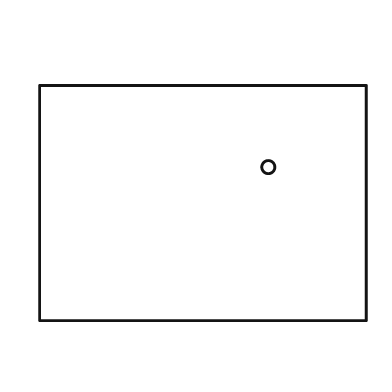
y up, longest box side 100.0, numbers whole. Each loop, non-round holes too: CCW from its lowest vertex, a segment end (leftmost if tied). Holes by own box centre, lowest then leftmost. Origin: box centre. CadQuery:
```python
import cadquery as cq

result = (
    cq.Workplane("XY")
    .moveTo(-50.0, -36.0)
    .lineTo(50.0, -36.0)
    .lineTo(50.0, 36.0)
    .lineTo(-50.0, 36.0)
    .close()
    .moveTo(20.0, 11.0)
    .circle(2.0)
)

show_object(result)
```